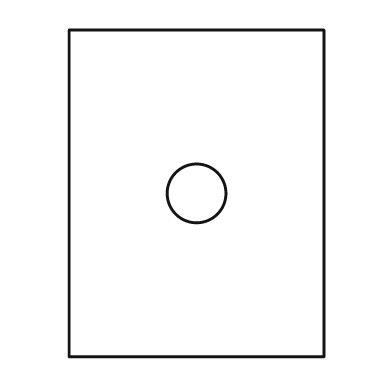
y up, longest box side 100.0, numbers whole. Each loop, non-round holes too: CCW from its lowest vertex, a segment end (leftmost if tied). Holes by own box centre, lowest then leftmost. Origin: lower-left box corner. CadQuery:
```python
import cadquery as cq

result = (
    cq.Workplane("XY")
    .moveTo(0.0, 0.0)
    .lineTo(78.0, 0.0)
    .lineTo(78.0, 100.0)
    .lineTo(0.0, 100.0)
    .close()
    .moveTo(39.0, 50.0)
    .circle(9.0)
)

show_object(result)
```